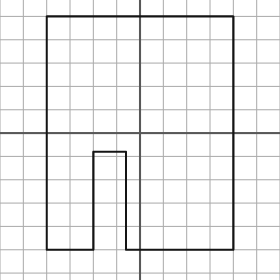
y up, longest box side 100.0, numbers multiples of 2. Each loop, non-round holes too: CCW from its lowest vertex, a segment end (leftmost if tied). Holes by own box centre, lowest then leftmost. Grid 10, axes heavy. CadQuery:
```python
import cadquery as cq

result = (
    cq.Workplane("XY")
    .moveTo(-40.0, -50.0)
    .lineTo(-20.0, -50.0)
    .lineTo(-20.0, -8.0)
    .lineTo(-6.0, -8.0)
    .lineTo(-6.0, -50.0)
    .lineTo(40.0, -50.0)
    .lineTo(40.0, 50.0)
    .lineTo(-40.0, 50.0)
    .close()
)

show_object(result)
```